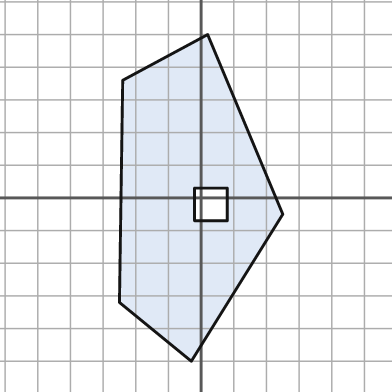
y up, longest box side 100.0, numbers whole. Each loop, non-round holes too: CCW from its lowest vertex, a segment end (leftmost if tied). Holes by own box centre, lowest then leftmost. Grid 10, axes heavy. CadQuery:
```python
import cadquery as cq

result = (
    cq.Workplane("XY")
    .moveTo(-3.0, -50.0)
    .lineTo(25.0, -5.0)
    .lineTo(2.0, 50.0)
    .lineTo(-24.0, 36.0)
    .lineTo(-25.0, -32.0)
    .close()
    .moveTo(-2.0, -7.0)
    .lineTo(8.0, -7.0)
    .lineTo(8.0, 3.0)
    .lineTo(-2.0, 3.0)
    .close()
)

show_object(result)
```